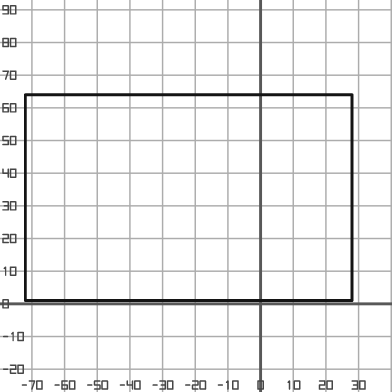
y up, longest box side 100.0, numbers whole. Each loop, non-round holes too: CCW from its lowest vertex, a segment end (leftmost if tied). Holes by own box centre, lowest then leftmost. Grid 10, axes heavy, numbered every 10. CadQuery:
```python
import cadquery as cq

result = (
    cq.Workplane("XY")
    .moveTo(-72.0, 1.0)
    .lineTo(28.0, 1.0)
    .lineTo(28.0, 64.0)
    .lineTo(-72.0, 64.0)
    .close()
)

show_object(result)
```